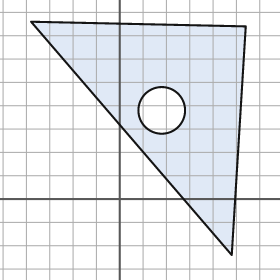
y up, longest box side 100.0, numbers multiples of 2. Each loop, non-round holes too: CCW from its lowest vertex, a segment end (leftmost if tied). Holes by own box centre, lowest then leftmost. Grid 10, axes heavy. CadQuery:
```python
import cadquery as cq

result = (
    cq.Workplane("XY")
    .moveTo(48.0, -24.0)
    .lineTo(54.0, 74.0)
    .lineTo(-38.0, 76.0)
    .close()
    .moveTo(18.0, 38.0)
    .circle(10.0)
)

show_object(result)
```